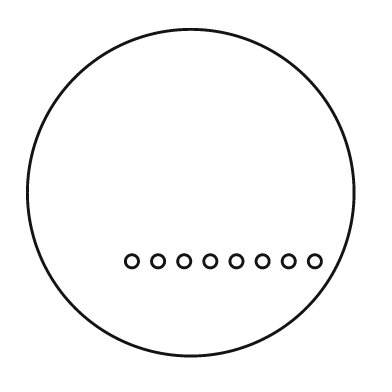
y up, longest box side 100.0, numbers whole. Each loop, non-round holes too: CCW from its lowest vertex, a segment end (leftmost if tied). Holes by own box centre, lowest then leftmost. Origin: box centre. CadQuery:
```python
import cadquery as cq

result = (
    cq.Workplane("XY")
    .moveTo(0.0, 0.0)
    .circle(50.0)
    .moveTo(-18.0, -21.0)
    .circle(2.0)
    .moveTo(-10.0, -21.0)
    .circle(2.0)
    .moveTo(-2.0, -21.0)
    .circle(2.0)
    .moveTo(6.0, -21.0)
    .circle(2.0)
    .moveTo(14.0, -21.0)
    .circle(2.0)
    .moveTo(22.0, -21.0)
    .circle(2.0)
    .moveTo(30.0, -21.0)
    .circle(2.0)
    .moveTo(38.0, -21.0)
    .circle(2.0)
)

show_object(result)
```